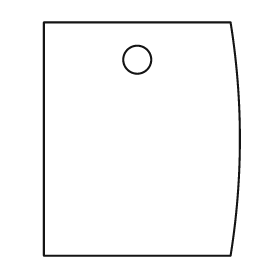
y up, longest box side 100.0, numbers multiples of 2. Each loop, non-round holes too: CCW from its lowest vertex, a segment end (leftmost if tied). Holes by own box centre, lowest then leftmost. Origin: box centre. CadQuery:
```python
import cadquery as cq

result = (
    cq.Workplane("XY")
    .moveTo(-42.0, -50.0)
    .lineTo(38.0, -50.0)
    .threePointArc((42.0, 0.0), (38.0, 50.0))
    .lineTo(-42.0, 50.0)
    .close()
    .moveTo(-2.0, 34.0)
    .circle(6.0)
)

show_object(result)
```